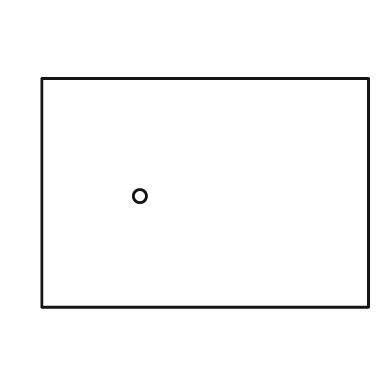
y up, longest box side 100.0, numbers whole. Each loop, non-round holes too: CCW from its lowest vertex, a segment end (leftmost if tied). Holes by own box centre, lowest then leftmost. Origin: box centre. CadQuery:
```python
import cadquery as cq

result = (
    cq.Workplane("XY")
    .moveTo(-50.0, -35.0)
    .lineTo(50.0, -35.0)
    .lineTo(50.0, 35.0)
    .lineTo(-50.0, 35.0)
    .close()
    .moveTo(-20.0, -1.0)
    .circle(2.0)
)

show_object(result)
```